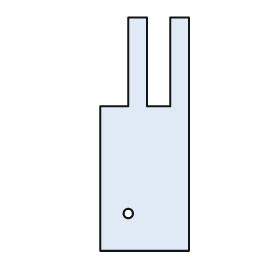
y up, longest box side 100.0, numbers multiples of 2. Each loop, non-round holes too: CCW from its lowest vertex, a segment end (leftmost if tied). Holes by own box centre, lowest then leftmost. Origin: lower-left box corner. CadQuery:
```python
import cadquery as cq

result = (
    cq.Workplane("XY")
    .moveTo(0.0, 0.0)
    .lineTo(38.0, 0.0)
    .lineTo(38.0, 100.0)
    .lineTo(30.0, 100.0)
    .lineTo(30.0, 62.0)
    .lineTo(20.0, 62.0)
    .lineTo(20.0, 100.0)
    .lineTo(12.0, 100.0)
    .lineTo(12.0, 62.0)
    .lineTo(0.0, 62.0)
    .close()
    .moveTo(12.0, 16.0)
    .circle(2.0)
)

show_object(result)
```